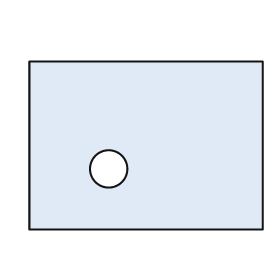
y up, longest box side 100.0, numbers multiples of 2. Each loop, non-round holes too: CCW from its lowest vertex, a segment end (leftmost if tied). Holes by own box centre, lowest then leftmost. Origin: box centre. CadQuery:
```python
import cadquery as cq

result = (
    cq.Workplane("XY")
    .moveTo(-50.0, -36.0)
    .lineTo(50.0, -36.0)
    .lineTo(50.0, 36.0)
    .lineTo(-50.0, 36.0)
    .close()
    .moveTo(-16.0, -10.0)
    .circle(8.0)
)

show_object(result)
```